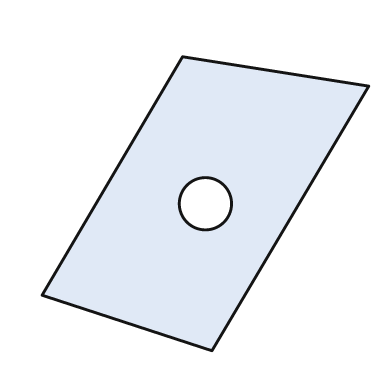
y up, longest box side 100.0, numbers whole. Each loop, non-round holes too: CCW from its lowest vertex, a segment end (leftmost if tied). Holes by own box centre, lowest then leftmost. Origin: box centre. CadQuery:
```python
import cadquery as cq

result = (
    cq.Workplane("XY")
    .moveTo(2.0, -45.0)
    .lineTo(50.0, 36.0)
    .lineTo(-7.0, 45.0)
    .lineTo(-50.0, -28.0)
    .close()
    .moveTo(0.0, 0.0)
    .circle(8.0)
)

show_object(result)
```